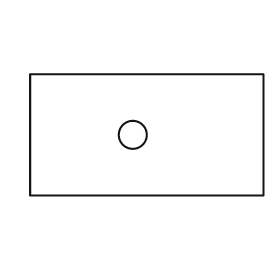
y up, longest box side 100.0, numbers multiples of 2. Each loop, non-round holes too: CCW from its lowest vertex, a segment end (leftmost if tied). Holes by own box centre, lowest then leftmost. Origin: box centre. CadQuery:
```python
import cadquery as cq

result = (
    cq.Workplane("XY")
    .moveTo(-50.0, -26.0)
    .lineTo(50.0, -26.0)
    .lineTo(50.0, 26.0)
    .lineTo(-50.0, 26.0)
    .close()
    .moveTo(-6.0, 0.0)
    .circle(6.0)
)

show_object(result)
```